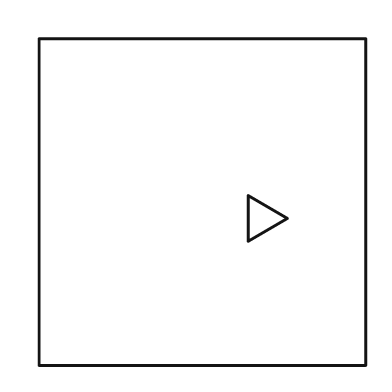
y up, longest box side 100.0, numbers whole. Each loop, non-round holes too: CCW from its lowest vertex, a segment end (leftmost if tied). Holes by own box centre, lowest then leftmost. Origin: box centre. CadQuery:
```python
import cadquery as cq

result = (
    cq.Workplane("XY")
    .moveTo(-50.0, -50.0)
    .lineTo(50.0, -50.0)
    .lineTo(50.0, 50.0)
    .lineTo(-50.0, 50.0)
    .close()
    .moveTo(14.0, -12.0)
    .lineTo(26.0, -5.0)
    .lineTo(14.0, 2.0)
    .close()
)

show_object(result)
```